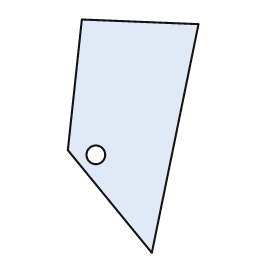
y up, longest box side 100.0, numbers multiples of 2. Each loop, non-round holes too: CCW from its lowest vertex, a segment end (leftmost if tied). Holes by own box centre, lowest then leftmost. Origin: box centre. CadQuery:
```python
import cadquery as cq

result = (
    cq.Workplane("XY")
    .moveTo(8.0, -50.0)
    .lineTo(28.0, 48.0)
    .lineTo(-22.0, 50.0)
    .lineTo(-28.0, -6.0)
    .close()
    .moveTo(-16.0, -8.0)
    .circle(4.0)
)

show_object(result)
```